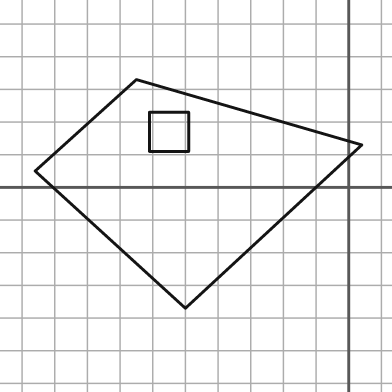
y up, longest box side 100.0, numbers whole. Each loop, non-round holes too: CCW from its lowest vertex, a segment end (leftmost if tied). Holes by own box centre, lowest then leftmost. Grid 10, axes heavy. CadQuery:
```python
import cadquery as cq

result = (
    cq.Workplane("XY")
    .moveTo(-50.0, -37.0)
    .lineTo(4.0, 13.0)
    .lineTo(-65.0, 33.0)
    .lineTo(-96.0, 5.0)
    .close()
    .moveTo(-61.0, 11.0)
    .lineTo(-49.0, 11.0)
    .lineTo(-49.0, 23.0)
    .lineTo(-61.0, 23.0)
    .close()
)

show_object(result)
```